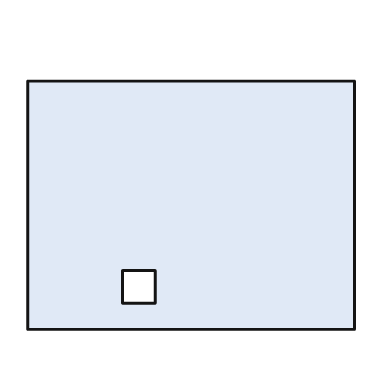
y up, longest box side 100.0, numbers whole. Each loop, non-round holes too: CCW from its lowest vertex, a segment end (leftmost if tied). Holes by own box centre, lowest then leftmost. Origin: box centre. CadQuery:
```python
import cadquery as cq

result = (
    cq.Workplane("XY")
    .moveTo(-50.0, -38.0)
    .lineTo(50.0, -38.0)
    .lineTo(50.0, 38.0)
    .lineTo(-50.0, 38.0)
    .close()
    .moveTo(-21.0, -30.0)
    .lineTo(-11.0, -30.0)
    .lineTo(-11.0, -20.0)
    .lineTo(-21.0, -20.0)
    .close()
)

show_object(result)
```